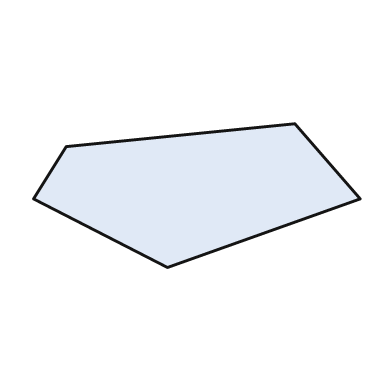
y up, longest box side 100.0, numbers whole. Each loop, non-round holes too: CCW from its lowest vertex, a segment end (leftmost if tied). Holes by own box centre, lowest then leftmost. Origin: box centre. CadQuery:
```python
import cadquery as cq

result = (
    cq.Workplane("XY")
    .moveTo(-9.0, -22.0)
    .lineTo(50.0, -1.0)
    .lineTo(30.0, 22.0)
    .lineTo(-40.0, 15.0)
    .lineTo(-50.0, -1.0)
    .close()
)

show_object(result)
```